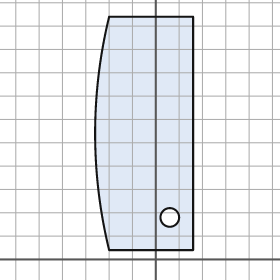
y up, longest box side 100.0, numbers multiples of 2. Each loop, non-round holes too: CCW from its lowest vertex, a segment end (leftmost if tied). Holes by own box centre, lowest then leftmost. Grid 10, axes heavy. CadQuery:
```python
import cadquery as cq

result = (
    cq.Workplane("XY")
    .moveTo(-20.0, 4.0)
    .lineTo(16.0, 4.0)
    .lineTo(16.0, 104.0)
    .lineTo(-20.0, 104.0)
    .threePointArc((-26.0, 54.0), (-20.0, 4.0))
    .close()
    .moveTo(6.0, 18.0)
    .circle(4.0)
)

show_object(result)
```